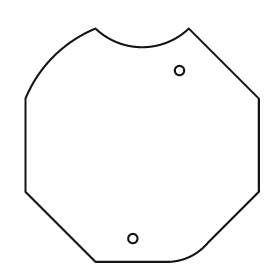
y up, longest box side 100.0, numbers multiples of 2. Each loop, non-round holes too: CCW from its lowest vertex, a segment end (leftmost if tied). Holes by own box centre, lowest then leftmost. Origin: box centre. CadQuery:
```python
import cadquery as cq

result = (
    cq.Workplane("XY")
    .moveTo(-20.0, -50.0)
    .lineTo(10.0, -50.0)
    .threePointArc((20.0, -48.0), (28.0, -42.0))
    .lineTo(50.0, -20.0)
    .lineTo(50.0, 20.0)
    .lineTo(20.0, 50.0)
    .threePointArc((0.0, 42.0), (-20.0, 50.0))
    .threePointArc((-38.0, 38.0), (-50.0, 20.0))
    .lineTo(-50.0, -20.0)
    .close()
    .moveTo(-4.0, -40.0)
    .circle(2.0)
    .moveTo(16.0, 32.0)
    .circle(2.0)
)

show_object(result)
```